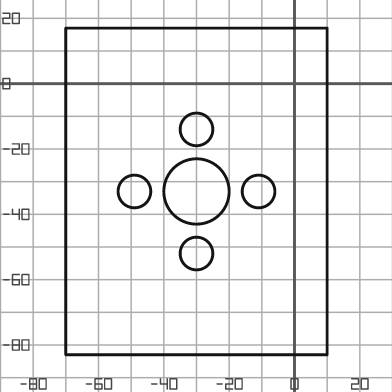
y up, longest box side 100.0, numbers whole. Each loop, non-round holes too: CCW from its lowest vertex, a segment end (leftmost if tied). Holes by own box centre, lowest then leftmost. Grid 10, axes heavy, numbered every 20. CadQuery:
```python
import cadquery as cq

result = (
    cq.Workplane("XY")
    .moveTo(-70.0, -83.0)
    .lineTo(10.0, -83.0)
    .lineTo(10.0, 17.0)
    .lineTo(-70.0, 17.0)
    .close()
    .moveTo(-30.0, -52.0)
    .circle(5.0)
    .moveTo(-49.0, -33.0)
    .circle(5.0)
    .moveTo(-30.0, -33.0)
    .circle(10.0)
    .moveTo(-11.0, -33.0)
    .circle(5.0)
    .moveTo(-30.0, -14.0)
    .circle(5.0)
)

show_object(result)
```